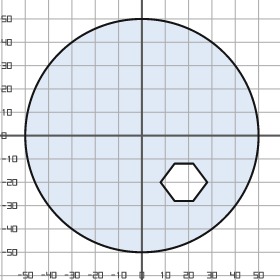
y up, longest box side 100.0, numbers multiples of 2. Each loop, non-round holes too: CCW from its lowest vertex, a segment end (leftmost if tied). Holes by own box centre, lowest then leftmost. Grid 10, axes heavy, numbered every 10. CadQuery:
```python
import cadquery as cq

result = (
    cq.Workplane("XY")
    .moveTo(0.0, 0.0)
    .circle(50.0)
    .moveTo(14.0, -28.0)
    .lineTo(22.0, -28.0)
    .lineTo(28.0, -20.0)
    .lineTo(22.0, -12.0)
    .lineTo(14.0, -12.0)
    .lineTo(8.0, -20.0)
    .close()
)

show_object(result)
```